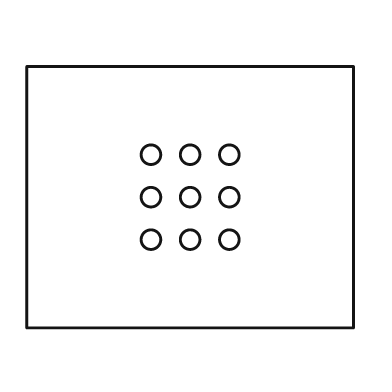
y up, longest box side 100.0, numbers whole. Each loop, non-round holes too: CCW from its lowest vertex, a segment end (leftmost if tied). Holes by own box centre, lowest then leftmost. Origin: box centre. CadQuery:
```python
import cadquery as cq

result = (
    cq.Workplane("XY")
    .moveTo(-50.0, -40.0)
    .lineTo(50.0, -40.0)
    .lineTo(50.0, 40.0)
    .lineTo(-50.0, 40.0)
    .close()
    .moveTo(-12.0, -13.0)
    .circle(3.0)
    .moveTo(0.0, -13.0)
    .circle(3.0)
    .moveTo(12.0, -13.0)
    .circle(3.0)
    .moveTo(-12.0, 0.0)
    .circle(3.0)
    .moveTo(0.0, 0.0)
    .circle(3.0)
    .moveTo(12.0, 0.0)
    .circle(3.0)
    .moveTo(-12.0, 13.0)
    .circle(3.0)
    .moveTo(0.0, 13.0)
    .circle(3.0)
    .moveTo(12.0, 13.0)
    .circle(3.0)
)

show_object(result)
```